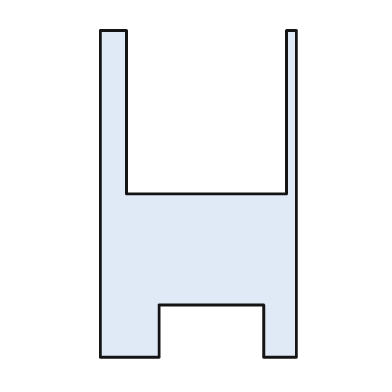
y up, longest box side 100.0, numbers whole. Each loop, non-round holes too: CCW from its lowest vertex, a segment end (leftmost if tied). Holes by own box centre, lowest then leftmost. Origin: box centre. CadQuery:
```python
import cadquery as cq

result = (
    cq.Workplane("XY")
    .moveTo(-30.0, -50.0)
    .lineTo(-12.0, -50.0)
    .lineTo(-12.0, -34.0)
    .lineTo(20.0, -34.0)
    .lineTo(20.0, -50.0)
    .lineTo(30.0, -50.0)
    .lineTo(30.0, 50.0)
    .lineTo(27.0, 50.0)
    .lineTo(27.0, 0.0)
    .lineTo(-22.0, 0.0)
    .lineTo(-22.0, 50.0)
    .lineTo(-30.0, 50.0)
    .close()
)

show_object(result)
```